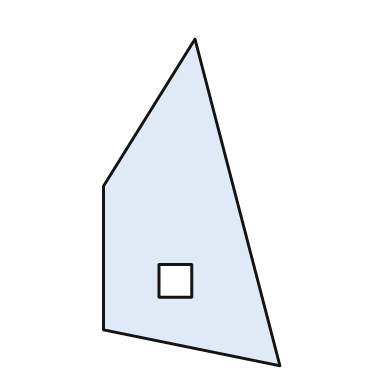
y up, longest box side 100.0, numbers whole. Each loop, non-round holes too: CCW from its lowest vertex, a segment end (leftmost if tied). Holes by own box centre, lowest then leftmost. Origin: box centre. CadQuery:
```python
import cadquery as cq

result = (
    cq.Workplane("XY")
    .moveTo(27.0, -50.0)
    .lineTo(1.0, 50.0)
    .lineTo(-27.0, 5.0)
    .lineTo(-27.0, -39.0)
    .close()
    .moveTo(-10.0, -29.0)
    .lineTo(0.0, -29.0)
    .lineTo(0.0, -19.0)
    .lineTo(-10.0, -19.0)
    .close()
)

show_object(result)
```